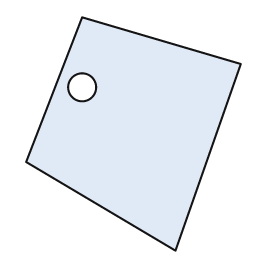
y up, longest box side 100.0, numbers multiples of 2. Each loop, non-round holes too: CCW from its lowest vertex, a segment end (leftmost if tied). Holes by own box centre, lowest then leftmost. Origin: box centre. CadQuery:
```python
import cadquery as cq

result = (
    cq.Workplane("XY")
    .moveTo(18.0, -50.0)
    .lineTo(46.0, 30.0)
    .lineTo(-22.0, 50.0)
    .lineTo(-46.0, -12.0)
    .close()
    .moveTo(-22.0, 20.0)
    .circle(6.0)
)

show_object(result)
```